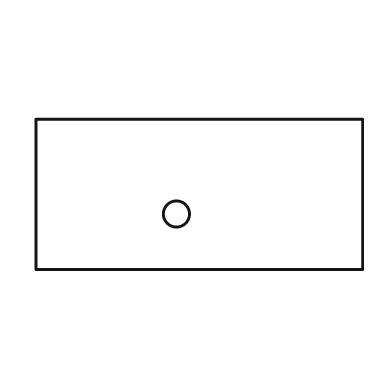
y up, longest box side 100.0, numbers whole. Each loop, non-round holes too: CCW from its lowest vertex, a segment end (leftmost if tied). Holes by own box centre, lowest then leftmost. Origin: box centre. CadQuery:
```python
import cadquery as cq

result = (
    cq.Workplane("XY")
    .moveTo(-50.0, -23.0)
    .lineTo(50.0, -23.0)
    .lineTo(50.0, 23.0)
    .lineTo(-50.0, 23.0)
    .close()
    .moveTo(-7.0, -6.0)
    .circle(4.0)
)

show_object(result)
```